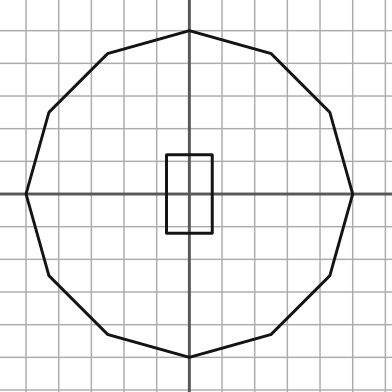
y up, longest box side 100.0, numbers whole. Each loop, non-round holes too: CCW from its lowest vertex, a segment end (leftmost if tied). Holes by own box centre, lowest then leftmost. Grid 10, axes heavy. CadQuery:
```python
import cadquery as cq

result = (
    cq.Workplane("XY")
    .moveTo(0.0, -50.0)
    .lineTo(25.0, -43.0)
    .lineTo(43.0, -25.0)
    .lineTo(50.0, 0.0)
    .lineTo(43.0, 25.0)
    .lineTo(25.0, 43.0)
    .lineTo(0.0, 50.0)
    .lineTo(-25.0, 43.0)
    .lineTo(-43.0, 25.0)
    .lineTo(-50.0, 0.0)
    .lineTo(-43.0, -25.0)
    .lineTo(-25.0, -43.0)
    .close()
    .moveTo(-7.0, -12.0)
    .lineTo(7.0, -12.0)
    .lineTo(7.0, 12.0)
    .lineTo(-7.0, 12.0)
    .close()
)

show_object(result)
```